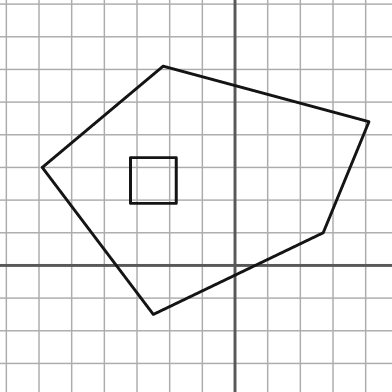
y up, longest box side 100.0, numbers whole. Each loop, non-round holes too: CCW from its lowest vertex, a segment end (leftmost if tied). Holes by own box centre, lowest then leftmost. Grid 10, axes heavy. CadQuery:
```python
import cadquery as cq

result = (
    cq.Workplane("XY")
    .moveTo(-25.0, -15.0)
    .lineTo(27.0, 10.0)
    .lineTo(41.0, 44.0)
    .lineTo(-22.0, 61.0)
    .lineTo(-59.0, 30.0)
    .close()
    .moveTo(-32.0, 19.0)
    .lineTo(-18.0, 19.0)
    .lineTo(-18.0, 33.0)
    .lineTo(-32.0, 33.0)
    .close()
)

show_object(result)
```